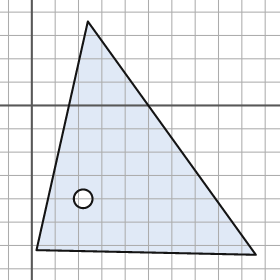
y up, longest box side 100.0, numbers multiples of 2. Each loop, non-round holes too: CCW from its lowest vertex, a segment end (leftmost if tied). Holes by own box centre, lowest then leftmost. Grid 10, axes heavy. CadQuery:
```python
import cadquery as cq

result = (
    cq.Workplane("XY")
    .moveTo(96.0, -64.0)
    .lineTo(24.0, 36.0)
    .lineTo(2.0, -62.0)
    .close()
    .moveTo(22.0, -40.0)
    .circle(4.0)
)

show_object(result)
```